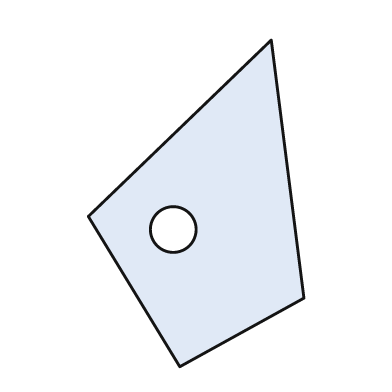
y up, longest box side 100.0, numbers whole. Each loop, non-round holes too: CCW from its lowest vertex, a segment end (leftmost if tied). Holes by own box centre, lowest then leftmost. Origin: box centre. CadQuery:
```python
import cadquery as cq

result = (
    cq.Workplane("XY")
    .moveTo(-5.0, -50.0)
    .lineTo(33.0, -29.0)
    .lineTo(23.0, 50.0)
    .lineTo(-33.0, -4.0)
    .close()
    .moveTo(-7.0, -8.0)
    .circle(7.0)
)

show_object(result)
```